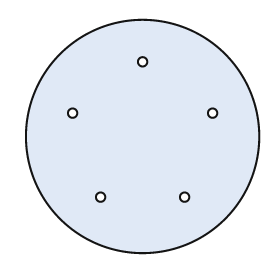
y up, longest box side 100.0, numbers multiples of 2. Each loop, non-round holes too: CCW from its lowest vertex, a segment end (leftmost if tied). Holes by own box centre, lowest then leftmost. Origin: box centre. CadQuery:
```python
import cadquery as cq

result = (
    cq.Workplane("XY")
    .moveTo(0.0, 0.0)
    .circle(50.0)
    .moveTo(-18.0, -26.0)
    .circle(2.0)
    .moveTo(18.0, -26.0)
    .circle(2.0)
    .moveTo(-30.0, 10.0)
    .circle(2.0)
    .moveTo(30.0, 10.0)
    .circle(2.0)
    .moveTo(0.0, 32.0)
    .circle(2.0)
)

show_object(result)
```